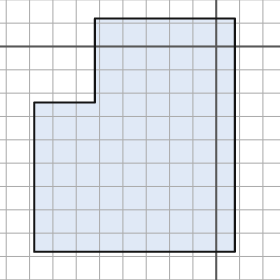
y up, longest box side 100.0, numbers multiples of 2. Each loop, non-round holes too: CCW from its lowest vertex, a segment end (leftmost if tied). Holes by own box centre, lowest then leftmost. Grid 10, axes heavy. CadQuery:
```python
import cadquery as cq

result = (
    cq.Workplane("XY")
    .moveTo(-78.0, -88.0)
    .lineTo(8.0, -88.0)
    .lineTo(8.0, 12.0)
    .lineTo(-52.0, 12.0)
    .lineTo(-52.0, -24.0)
    .lineTo(-78.0, -24.0)
    .close()
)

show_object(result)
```